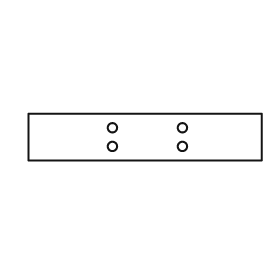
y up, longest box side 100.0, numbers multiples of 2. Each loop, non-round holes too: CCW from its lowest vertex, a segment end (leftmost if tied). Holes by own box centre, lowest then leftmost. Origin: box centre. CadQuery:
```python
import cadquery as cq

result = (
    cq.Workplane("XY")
    .moveTo(-50.0, -10.0)
    .lineTo(50.0, -10.0)
    .lineTo(50.0, 10.0)
    .lineTo(-50.0, 10.0)
    .close()
    .moveTo(-14.0, -4.0)
    .circle(2.0)
    .moveTo(16.0, -4.0)
    .circle(2.0)
    .moveTo(-14.0, 4.0)
    .circle(2.0)
    .moveTo(16.0, 4.0)
    .circle(2.0)
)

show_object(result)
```